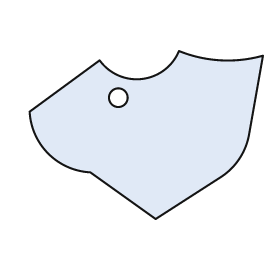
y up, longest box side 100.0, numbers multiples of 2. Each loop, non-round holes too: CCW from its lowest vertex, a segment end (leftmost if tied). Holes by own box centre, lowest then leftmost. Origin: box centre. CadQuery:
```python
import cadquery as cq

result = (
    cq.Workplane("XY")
    .moveTo(4.0, -36.0)
    .lineTo(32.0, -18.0)
    .threePointArc((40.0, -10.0), (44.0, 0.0))
    .lineTo(50.0, 34.0)
    .threePointArc((32.0, 32.0), (14.0, 36.0))
    .threePointArc((-2.0, 24.0), (-20.0, 32.0))
    .lineTo(-50.0, 10.0)
    .threePointArc((-42.0, -8.0), (-24.0, -16.0))
    .close()
    .moveTo(-12.0, 16.0)
    .circle(4.0)
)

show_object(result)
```